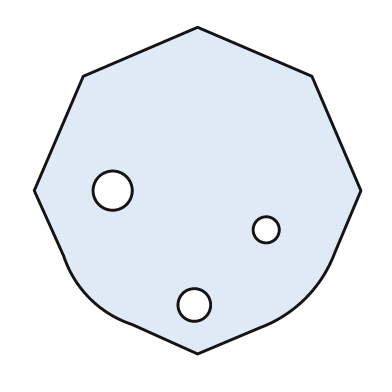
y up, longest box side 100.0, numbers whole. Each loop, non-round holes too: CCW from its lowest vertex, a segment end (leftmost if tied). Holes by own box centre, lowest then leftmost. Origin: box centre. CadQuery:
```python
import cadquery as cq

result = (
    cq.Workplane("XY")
    .moveTo(0.0, -50.0)
    .lineTo(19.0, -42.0)
    .threePointArc((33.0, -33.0), (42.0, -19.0))
    .lineTo(50.0, 0.0)
    .lineTo(35.0, 35.0)
    .lineTo(0.0, 50.0)
    .lineTo(-35.0, 35.0)
    .lineTo(-50.0, 0.0)
    .lineTo(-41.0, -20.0)
    .threePointArc((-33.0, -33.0), (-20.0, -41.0))
    .close()
    .moveTo(-1.0, -35.0)
    .circle(5.0)
    .moveTo(21.0, -12.0)
    .circle(4.0)
    .moveTo(-26.0, 0.0)
    .circle(6.0)
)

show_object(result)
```